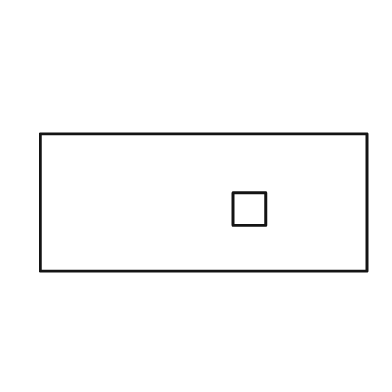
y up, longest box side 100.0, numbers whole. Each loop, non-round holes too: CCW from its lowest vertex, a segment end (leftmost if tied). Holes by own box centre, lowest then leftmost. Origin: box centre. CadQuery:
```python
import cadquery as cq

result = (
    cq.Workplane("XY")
    .moveTo(-50.0, -21.0)
    .lineTo(50.0, -21.0)
    .lineTo(50.0, 21.0)
    .lineTo(-50.0, 21.0)
    .close()
    .moveTo(9.0, -7.0)
    .lineTo(19.0, -7.0)
    .lineTo(19.0, 3.0)
    .lineTo(9.0, 3.0)
    .close()
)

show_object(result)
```